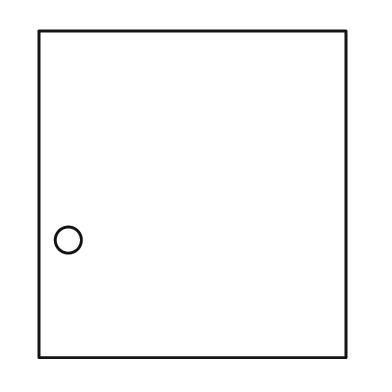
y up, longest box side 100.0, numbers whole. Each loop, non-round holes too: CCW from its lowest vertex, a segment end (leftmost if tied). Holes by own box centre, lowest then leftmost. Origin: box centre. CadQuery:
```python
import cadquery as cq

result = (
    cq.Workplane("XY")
    .moveTo(-47.0, -50.0)
    .lineTo(47.0, -50.0)
    .lineTo(47.0, 50.0)
    .lineTo(-47.0, 50.0)
    .close()
    .moveTo(-38.0, -14.0)
    .circle(4.0)
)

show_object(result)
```